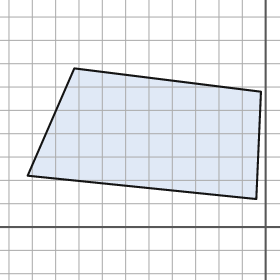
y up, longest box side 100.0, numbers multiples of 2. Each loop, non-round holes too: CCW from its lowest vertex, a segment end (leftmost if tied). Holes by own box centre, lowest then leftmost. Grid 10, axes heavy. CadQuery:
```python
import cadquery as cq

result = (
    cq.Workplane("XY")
    .moveTo(-4.0, 12.0)
    .lineTo(-2.0, 58.0)
    .lineTo(-82.0, 68.0)
    .lineTo(-102.0, 22.0)
    .close()
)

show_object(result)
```